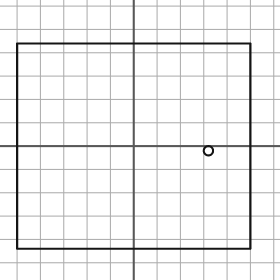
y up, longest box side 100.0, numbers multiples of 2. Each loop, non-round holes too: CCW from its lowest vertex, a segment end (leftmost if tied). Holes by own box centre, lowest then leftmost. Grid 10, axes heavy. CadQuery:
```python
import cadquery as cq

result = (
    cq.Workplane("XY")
    .moveTo(-50.0, -44.0)
    .lineTo(50.0, -44.0)
    .lineTo(50.0, 44.0)
    .lineTo(-50.0, 44.0)
    .close()
    .moveTo(32.0, -2.0)
    .circle(2.0)
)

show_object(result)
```